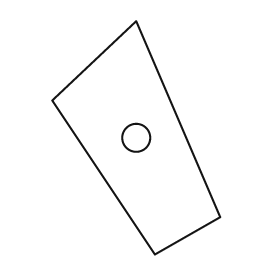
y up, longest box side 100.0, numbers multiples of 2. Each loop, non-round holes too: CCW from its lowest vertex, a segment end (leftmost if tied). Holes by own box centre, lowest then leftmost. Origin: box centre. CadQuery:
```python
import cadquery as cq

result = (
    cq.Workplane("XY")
    .moveTo(8.0, -50.0)
    .lineTo(36.0, -34.0)
    .lineTo(0.0, 50.0)
    .lineTo(-36.0, 16.0)
    .close()
    .moveTo(0.0, 0.0)
    .circle(6.0)
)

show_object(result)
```